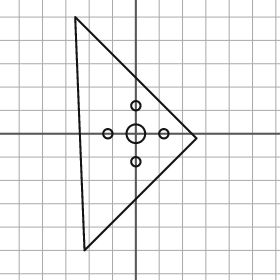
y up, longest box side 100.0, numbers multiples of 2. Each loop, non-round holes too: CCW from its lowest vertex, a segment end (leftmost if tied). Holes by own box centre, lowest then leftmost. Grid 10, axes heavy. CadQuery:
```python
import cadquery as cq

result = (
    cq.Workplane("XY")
    .moveTo(-22.0, -50.0)
    .lineTo(26.0, -2.0)
    .lineTo(-26.0, 50.0)
    .close()
    .moveTo(0.0, -12.0)
    .circle(2.0)
    .moveTo(-12.0, 0.0)
    .circle(2.0)
    .moveTo(0.0, 0.0)
    .circle(4.0)
    .moveTo(12.0, 0.0)
    .circle(2.0)
    .moveTo(0.0, 12.0)
    .circle(2.0)
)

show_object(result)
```